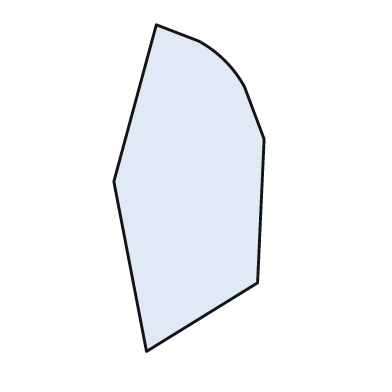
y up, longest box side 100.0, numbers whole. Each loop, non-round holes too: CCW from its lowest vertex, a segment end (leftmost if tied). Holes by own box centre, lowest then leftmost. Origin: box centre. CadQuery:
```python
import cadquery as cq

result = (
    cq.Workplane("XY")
    .moveTo(-13.0, -50.0)
    .lineTo(21.0, -29.0)
    .lineTo(23.0, 15.0)
    .lineTo(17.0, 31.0)
    .threePointArc((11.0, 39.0), (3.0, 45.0))
    .lineTo(-10.0, 50.0)
    .lineTo(-23.0, 2.0)
    .close()
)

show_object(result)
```